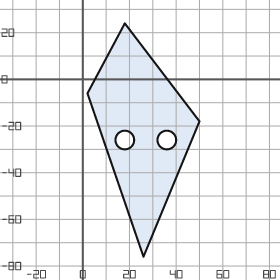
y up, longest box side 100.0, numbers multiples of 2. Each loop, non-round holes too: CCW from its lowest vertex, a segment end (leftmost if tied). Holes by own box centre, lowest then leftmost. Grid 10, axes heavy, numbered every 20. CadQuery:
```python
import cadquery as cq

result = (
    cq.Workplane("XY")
    .moveTo(26.0, -76.0)
    .lineTo(50.0, -18.0)
    .lineTo(18.0, 24.0)
    .lineTo(2.0, -6.0)
    .close()
    .moveTo(18.0, -26.0)
    .circle(4.0)
    .moveTo(36.0, -26.0)
    .circle(4.0)
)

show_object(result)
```